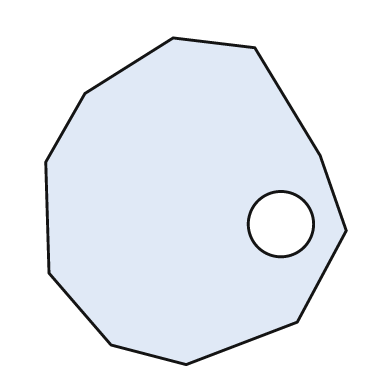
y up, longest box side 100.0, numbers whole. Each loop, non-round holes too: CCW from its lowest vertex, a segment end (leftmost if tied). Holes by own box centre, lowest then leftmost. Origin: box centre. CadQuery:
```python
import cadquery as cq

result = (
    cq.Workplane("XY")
    .moveTo(-3.0, -50.0)
    .lineTo(31.0, -37.0)
    .lineTo(46.0, -9.0)
    .lineTo(38.0, 14.0)
    .lineTo(18.0, 47.0)
    .lineTo(-7.0, 50.0)
    .lineTo(-34.0, 33.0)
    .lineTo(-46.0, 12.0)
    .lineTo(-45.0, -22.0)
    .lineTo(-26.0, -44.0)
    .close()
    .moveTo(26.0, -7.0)
    .circle(10.0)
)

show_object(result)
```